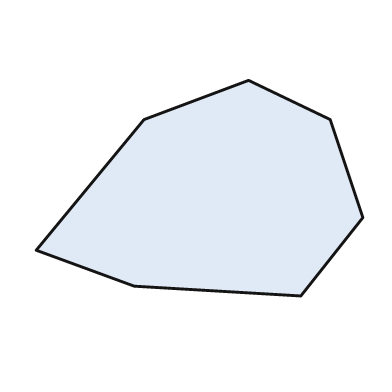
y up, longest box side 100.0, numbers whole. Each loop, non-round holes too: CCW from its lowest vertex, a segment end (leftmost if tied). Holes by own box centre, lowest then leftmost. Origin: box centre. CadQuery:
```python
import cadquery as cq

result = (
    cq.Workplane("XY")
    .moveTo(31.0, -33.0)
    .lineTo(50.0, -9.0)
    .lineTo(40.0, 21.0)
    .lineTo(15.0, 33.0)
    .lineTo(-17.0, 21.0)
    .lineTo(-50.0, -19.0)
    .lineTo(-20.0, -30.0)
    .close()
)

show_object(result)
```